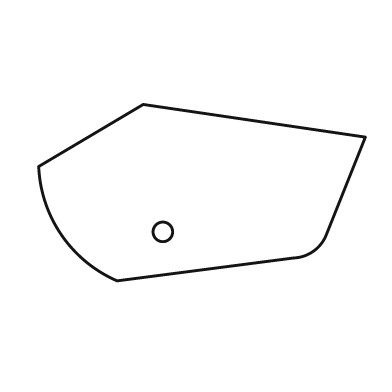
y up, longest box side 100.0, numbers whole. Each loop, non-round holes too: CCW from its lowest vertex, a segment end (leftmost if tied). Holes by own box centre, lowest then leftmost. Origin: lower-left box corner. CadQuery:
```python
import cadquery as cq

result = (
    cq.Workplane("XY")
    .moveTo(24.0, 0.0)
    .lineTo(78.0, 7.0)
    .threePointArc((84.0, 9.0), (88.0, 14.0))
    .lineTo(100.0, 44.0)
    .lineTo(32.0, 54.0)
    .lineTo(0.0, 35.0)
    .threePointArc((7.0, 14.0), (24.0, 0.0))
    .close()
    .moveTo(38.0, 15.0)
    .circle(3.0)
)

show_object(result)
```